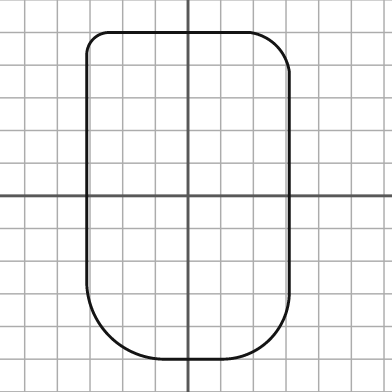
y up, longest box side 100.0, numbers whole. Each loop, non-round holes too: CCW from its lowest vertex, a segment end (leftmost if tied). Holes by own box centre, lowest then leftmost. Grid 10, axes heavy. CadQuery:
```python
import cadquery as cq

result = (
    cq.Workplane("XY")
    .moveTo(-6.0, -50.0)
    .lineTo(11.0, -50.0)
    .threePointArc((25.0, -44.0), (31.0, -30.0))
    .lineTo(31.0, 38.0)
    .threePointArc((27.0, 46.0), (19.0, 50.0))
    .lineTo(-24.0, 50.0)
    .threePointArc((-29.0, 48.0), (-31.0, 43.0))
    .lineTo(-31.0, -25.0)
    .threePointArc((-24.0, -43.0), (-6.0, -50.0))
    .close()
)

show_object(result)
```